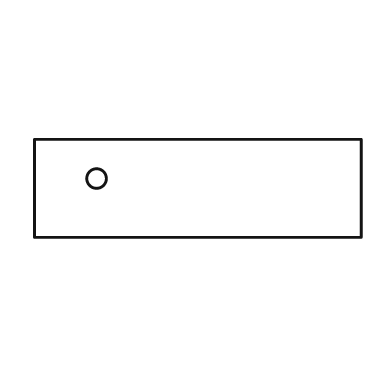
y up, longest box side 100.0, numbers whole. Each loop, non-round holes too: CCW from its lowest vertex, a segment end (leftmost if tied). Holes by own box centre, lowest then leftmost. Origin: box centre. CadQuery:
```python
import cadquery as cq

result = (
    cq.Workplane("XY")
    .moveTo(-50.0, -15.0)
    .lineTo(50.0, -15.0)
    .lineTo(50.0, 15.0)
    .lineTo(-50.0, 15.0)
    .close()
    .moveTo(-31.0, 3.0)
    .circle(3.0)
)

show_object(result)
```